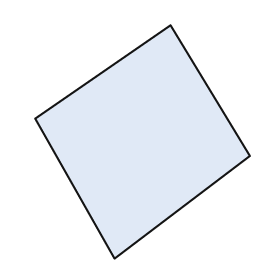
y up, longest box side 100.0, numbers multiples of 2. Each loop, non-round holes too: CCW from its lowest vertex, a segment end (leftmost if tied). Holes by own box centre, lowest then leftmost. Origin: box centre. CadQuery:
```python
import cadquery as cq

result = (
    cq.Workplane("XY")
    .moveTo(-12.0, -50.0)
    .lineTo(46.0, -6.0)
    .lineTo(12.0, 50.0)
    .lineTo(-46.0, 10.0)
    .close()
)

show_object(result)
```